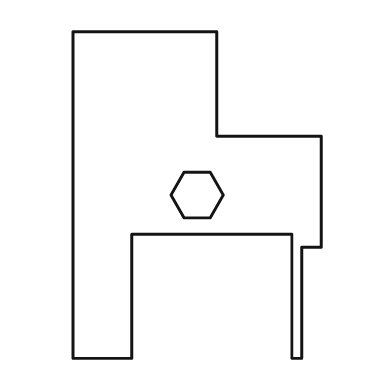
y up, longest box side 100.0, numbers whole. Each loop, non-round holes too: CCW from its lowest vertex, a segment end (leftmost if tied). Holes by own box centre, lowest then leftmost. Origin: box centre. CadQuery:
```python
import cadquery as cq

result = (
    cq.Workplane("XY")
    .moveTo(-38.0, -50.0)
    .lineTo(-20.0, -50.0)
    .lineTo(-20.0, -12.0)
    .lineTo(29.0, -12.0)
    .lineTo(29.0, -50.0)
    .lineTo(32.0, -50.0)
    .lineTo(32.0, -16.0)
    .lineTo(38.0, -16.0)
    .lineTo(38.0, 18.0)
    .lineTo(6.0, 18.0)
    .lineTo(6.0, 50.0)
    .lineTo(-38.0, 50.0)
    .close()
    .moveTo(-4.0, -7.0)
    .lineTo(4.0, -7.0)
    .lineTo(8.0, 0.0)
    .lineTo(4.0, 7.0)
    .lineTo(-4.0, 7.0)
    .lineTo(-8.0, 0.0)
    .close()
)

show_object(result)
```